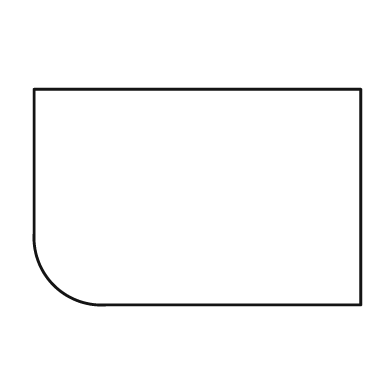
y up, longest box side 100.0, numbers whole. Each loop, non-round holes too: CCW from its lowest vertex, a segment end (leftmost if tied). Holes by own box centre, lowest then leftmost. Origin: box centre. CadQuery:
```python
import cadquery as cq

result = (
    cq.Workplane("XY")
    .moveTo(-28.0, -33.0)
    .lineTo(50.0, -33.0)
    .lineTo(50.0, 33.0)
    .lineTo(-50.0, 33.0)
    .lineTo(-50.0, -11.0)
    .threePointArc((-44.0, -27.0), (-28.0, -33.0))
    .close()
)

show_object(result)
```